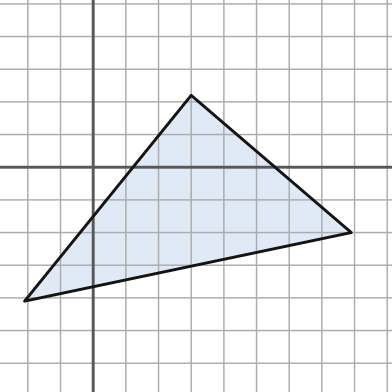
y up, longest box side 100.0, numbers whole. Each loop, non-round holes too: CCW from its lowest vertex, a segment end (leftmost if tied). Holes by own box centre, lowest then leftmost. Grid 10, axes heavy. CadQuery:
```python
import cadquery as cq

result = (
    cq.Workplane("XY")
    .moveTo(-21.0, -41.0)
    .lineTo(79.0, -20.0)
    .lineTo(30.0, 22.0)
    .close()
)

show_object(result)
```